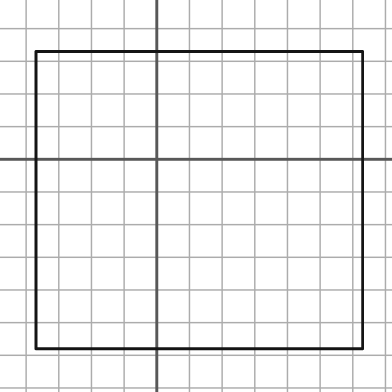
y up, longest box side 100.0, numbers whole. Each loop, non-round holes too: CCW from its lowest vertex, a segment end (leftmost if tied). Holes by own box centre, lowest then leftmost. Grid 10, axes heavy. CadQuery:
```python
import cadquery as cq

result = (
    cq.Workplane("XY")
    .moveTo(-37.0, -58.0)
    .lineTo(63.0, -58.0)
    .lineTo(63.0, 33.0)
    .lineTo(-37.0, 33.0)
    .close()
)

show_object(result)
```